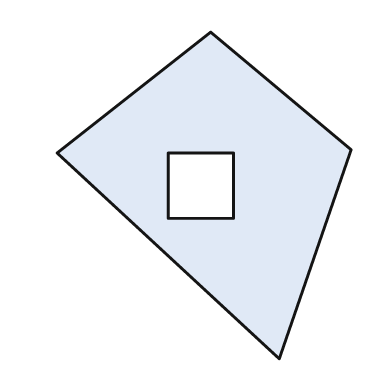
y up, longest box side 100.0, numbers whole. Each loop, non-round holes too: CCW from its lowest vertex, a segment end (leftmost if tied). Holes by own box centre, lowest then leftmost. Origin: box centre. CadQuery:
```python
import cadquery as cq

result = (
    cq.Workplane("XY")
    .moveTo(23.0, -50.0)
    .lineTo(45.0, 14.0)
    .lineTo(2.0, 50.0)
    .lineTo(-45.0, 13.0)
    .close()
    .moveTo(-11.0, -7.0)
    .lineTo(9.0, -7.0)
    .lineTo(9.0, 13.0)
    .lineTo(-11.0, 13.0)
    .close()
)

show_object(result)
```